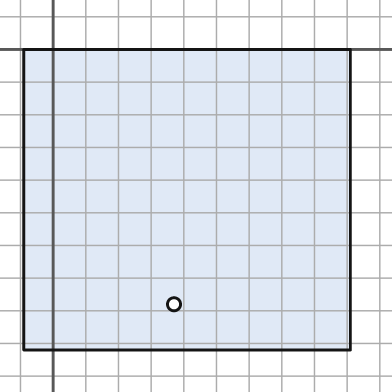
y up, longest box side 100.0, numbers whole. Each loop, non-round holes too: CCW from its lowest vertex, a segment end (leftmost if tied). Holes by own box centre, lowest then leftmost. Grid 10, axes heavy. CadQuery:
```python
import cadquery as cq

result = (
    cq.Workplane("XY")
    .moveTo(-9.0, -92.0)
    .lineTo(91.0, -92.0)
    .lineTo(91.0, 0.0)
    .lineTo(-9.0, 0.0)
    .close()
    .moveTo(37.0, -78.0)
    .circle(2.0)
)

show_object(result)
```